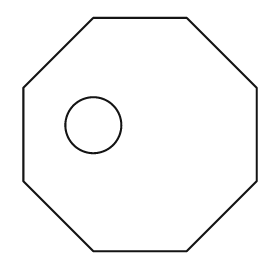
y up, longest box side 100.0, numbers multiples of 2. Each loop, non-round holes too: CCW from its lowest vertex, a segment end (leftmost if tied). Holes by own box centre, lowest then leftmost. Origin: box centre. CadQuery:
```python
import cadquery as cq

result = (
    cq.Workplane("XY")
    .moveTo(-20.0, -50.0)
    .lineTo(20.0, -50.0)
    .lineTo(50.0, -20.0)
    .lineTo(50.0, 20.0)
    .lineTo(20.0, 50.0)
    .lineTo(-20.0, 50.0)
    .lineTo(-50.0, 20.0)
    .lineTo(-50.0, -20.0)
    .close()
    .moveTo(-20.0, 4.0)
    .circle(12.0)
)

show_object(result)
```